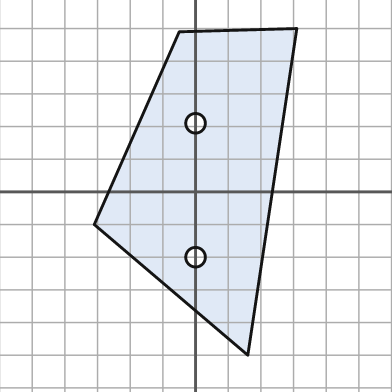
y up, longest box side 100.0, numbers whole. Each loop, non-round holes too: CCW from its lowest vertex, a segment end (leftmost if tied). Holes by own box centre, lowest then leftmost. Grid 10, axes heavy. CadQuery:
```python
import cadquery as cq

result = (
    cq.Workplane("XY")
    .moveTo(16.0, -50.0)
    .lineTo(31.0, 50.0)
    .lineTo(-5.0, 49.0)
    .lineTo(-31.0, -10.0)
    .close()
    .moveTo(0.0, -20.0)
    .circle(3.0)
    .moveTo(0.0, 21.0)
    .circle(3.0)
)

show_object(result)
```